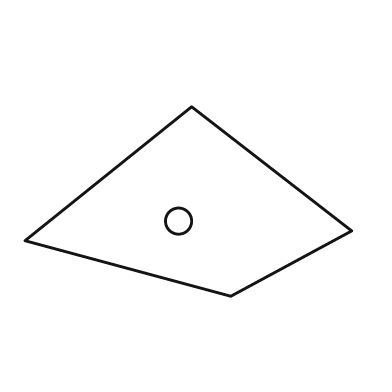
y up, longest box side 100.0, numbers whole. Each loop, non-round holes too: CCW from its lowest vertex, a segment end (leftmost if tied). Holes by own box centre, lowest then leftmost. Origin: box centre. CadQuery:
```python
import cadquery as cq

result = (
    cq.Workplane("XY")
    .moveTo(13.0, -29.0)
    .lineTo(50.0, -9.0)
    .lineTo(1.0, 29.0)
    .lineTo(-50.0, -12.0)
    .close()
    .moveTo(-3.0, -6.0)
    .circle(4.0)
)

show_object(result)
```